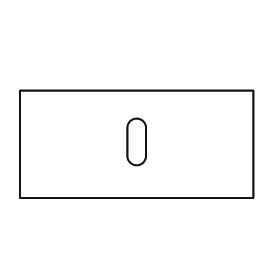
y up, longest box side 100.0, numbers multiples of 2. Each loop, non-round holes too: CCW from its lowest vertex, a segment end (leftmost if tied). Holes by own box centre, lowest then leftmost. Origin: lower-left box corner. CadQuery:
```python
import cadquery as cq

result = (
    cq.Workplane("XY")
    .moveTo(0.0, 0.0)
    .lineTo(100.0, 0.0)
    .lineTo(100.0, 46.0)
    .lineTo(0.0, 46.0)
    .close()
    .moveTo(46.0, 18.0)
    .threePointArc((50.0, 14.0), (54.0, 18.0))
    .lineTo(54.0, 30.0)
    .threePointArc((50.0, 34.0), (46.0, 30.0))
    .close()
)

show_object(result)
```